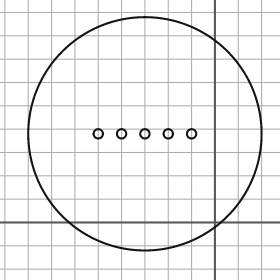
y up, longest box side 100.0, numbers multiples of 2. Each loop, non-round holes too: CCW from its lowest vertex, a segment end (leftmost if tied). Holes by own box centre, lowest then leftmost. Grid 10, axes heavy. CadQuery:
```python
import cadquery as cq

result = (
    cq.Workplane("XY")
    .moveTo(-30.0, 38.0)
    .circle(50.0)
    .moveTo(-50.0, 38.0)
    .circle(2.0)
    .moveTo(-40.0, 38.0)
    .circle(2.0)
    .moveTo(-30.0, 38.0)
    .circle(2.0)
    .moveTo(-20.0, 38.0)
    .circle(2.0)
    .moveTo(-10.0, 38.0)
    .circle(2.0)
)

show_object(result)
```